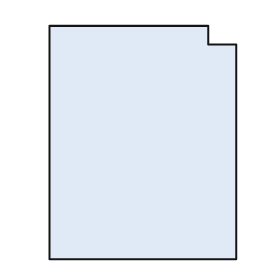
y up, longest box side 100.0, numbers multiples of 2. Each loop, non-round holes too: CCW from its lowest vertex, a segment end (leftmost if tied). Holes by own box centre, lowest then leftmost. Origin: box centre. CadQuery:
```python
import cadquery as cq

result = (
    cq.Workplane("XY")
    .moveTo(-40.0, -50.0)
    .lineTo(40.0, -50.0)
    .lineTo(40.0, 42.0)
    .lineTo(28.0, 42.0)
    .lineTo(28.0, 50.0)
    .lineTo(-40.0, 50.0)
    .close()
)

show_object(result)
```